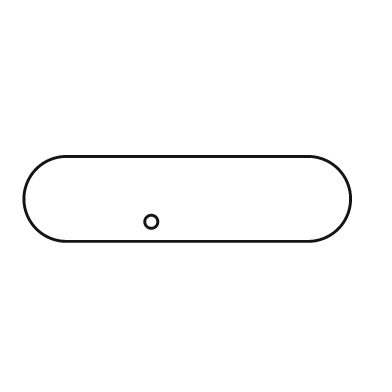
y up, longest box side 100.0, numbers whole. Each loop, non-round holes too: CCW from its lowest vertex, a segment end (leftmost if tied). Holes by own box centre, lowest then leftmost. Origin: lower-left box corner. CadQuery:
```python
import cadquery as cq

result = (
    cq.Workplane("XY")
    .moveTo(13.0, 0.0)
    .lineTo(87.0, 0.0)
    .threePointArc((100.0, 13.0), (87.0, 26.0))
    .lineTo(13.0, 26.0)
    .threePointArc((0.0, 13.0), (13.0, 0.0))
    .close()
    .moveTo(39.0, 6.0)
    .circle(2.0)
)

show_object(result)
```